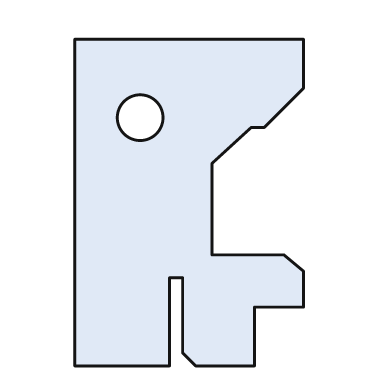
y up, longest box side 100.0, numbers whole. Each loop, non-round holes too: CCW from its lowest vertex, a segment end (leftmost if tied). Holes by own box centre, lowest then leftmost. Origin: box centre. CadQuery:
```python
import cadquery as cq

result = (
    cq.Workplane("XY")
    .moveTo(-35.0, -50.0)
    .lineTo(-6.0, -50.0)
    .lineTo(-6.0, -23.0)
    .lineTo(-2.0, -23.0)
    .lineTo(-2.0, -46.0)
    .lineTo(2.0, -50.0)
    .lineTo(20.0, -50.0)
    .lineTo(20.0, -32.0)
    .lineTo(35.0, -32.0)
    .lineTo(35.0, -21.0)
    .lineTo(29.0, -16.0)
    .lineTo(7.0, -16.0)
    .lineTo(7.0, 12.0)
    .lineTo(19.0, 23.0)
    .lineTo(23.0, 23.0)
    .lineTo(35.0, 35.0)
    .lineTo(35.0, 50.0)
    .lineTo(-35.0, 50.0)
    .close()
    .moveTo(-15.0, 26.0)
    .circle(7.0)
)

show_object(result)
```